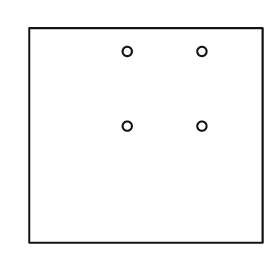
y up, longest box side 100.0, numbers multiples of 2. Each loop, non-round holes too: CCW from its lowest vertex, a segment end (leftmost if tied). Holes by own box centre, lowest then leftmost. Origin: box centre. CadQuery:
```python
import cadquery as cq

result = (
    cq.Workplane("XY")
    .moveTo(-50.0, -46.0)
    .lineTo(50.0, -46.0)
    .lineTo(50.0, 46.0)
    .lineTo(-50.0, 46.0)
    .close()
    .moveTo(-8.0, 4.0)
    .circle(2.0)
    .moveTo(24.0, 4.0)
    .circle(2.0)
    .moveTo(-8.0, 36.0)
    .circle(2.0)
    .moveTo(24.0, 36.0)
    .circle(2.0)
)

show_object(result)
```